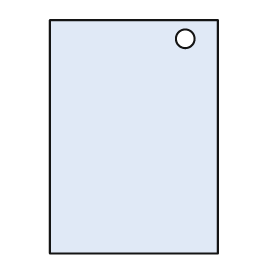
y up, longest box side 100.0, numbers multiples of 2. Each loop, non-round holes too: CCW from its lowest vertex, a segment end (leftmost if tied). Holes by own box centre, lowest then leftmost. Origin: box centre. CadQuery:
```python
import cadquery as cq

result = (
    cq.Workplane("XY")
    .moveTo(-36.0, -50.0)
    .lineTo(36.0, -50.0)
    .lineTo(36.0, 50.0)
    .lineTo(-36.0, 50.0)
    .close()
    .moveTo(22.0, 42.0)
    .circle(4.0)
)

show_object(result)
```